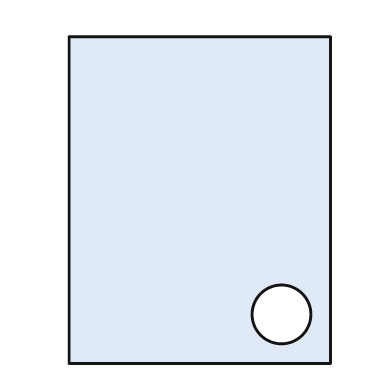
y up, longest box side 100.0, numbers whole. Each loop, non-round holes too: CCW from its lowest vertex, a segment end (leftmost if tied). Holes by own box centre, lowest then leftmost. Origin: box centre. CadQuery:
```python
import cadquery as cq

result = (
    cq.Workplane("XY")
    .moveTo(-40.0, -50.0)
    .lineTo(40.0, -50.0)
    .lineTo(40.0, 50.0)
    .lineTo(-40.0, 50.0)
    .close()
    .moveTo(25.0, -35.0)
    .circle(9.0)
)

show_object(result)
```